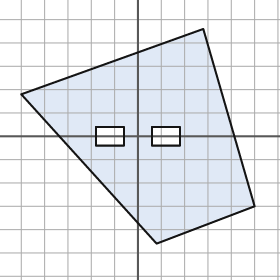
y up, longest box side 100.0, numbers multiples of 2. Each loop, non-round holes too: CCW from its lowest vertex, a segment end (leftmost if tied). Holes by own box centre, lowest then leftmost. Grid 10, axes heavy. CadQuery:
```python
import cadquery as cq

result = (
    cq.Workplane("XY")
    .moveTo(8.0, -46.0)
    .lineTo(50.0, -30.0)
    .lineTo(28.0, 46.0)
    .lineTo(-50.0, 18.0)
    .close()
    .moveTo(-18.0, -4.0)
    .lineTo(-6.0, -4.0)
    .lineTo(-6.0, 4.0)
    .lineTo(-18.0, 4.0)
    .close()
    .moveTo(6.0, -4.0)
    .lineTo(18.0, -4.0)
    .lineTo(18.0, 4.0)
    .lineTo(6.0, 4.0)
    .close()
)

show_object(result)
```